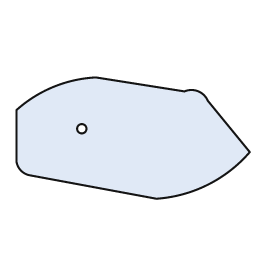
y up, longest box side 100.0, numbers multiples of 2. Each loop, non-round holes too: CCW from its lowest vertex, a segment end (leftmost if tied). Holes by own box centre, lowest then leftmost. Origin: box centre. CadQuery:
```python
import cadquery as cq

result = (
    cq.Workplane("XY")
    .moveTo(10.0, -26.0)
    .threePointArc((32.0, -20.0), (50.0, -6.0))
    .lineTo(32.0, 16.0)
    .threePointArc((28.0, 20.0), (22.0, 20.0))
    .lineTo(-16.0, 26.0)
    .threePointArc((-34.0, 22.0), (-50.0, 12.0))
    .lineTo(-50.0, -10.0)
    .threePointArc((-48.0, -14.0), (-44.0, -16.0))
    .close()
    .moveTo(-22.0, 4.0)
    .circle(2.0)
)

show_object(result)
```